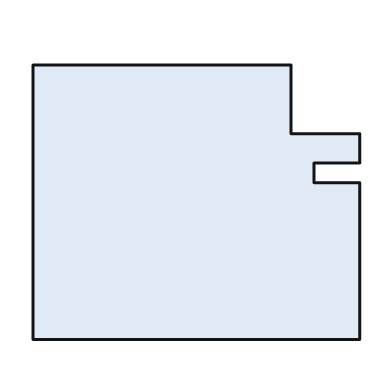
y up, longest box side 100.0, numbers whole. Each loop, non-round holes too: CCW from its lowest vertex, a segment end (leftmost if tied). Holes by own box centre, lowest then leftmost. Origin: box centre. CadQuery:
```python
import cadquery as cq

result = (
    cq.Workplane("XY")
    .moveTo(-50.0, -42.0)
    .lineTo(50.0, -42.0)
    .lineTo(50.0, 6.0)
    .lineTo(36.0, 6.0)
    .lineTo(36.0, 12.0)
    .lineTo(50.0, 12.0)
    .lineTo(50.0, 21.0)
    .lineTo(29.0, 21.0)
    .lineTo(29.0, 42.0)
    .lineTo(-50.0, 42.0)
    .close()
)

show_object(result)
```